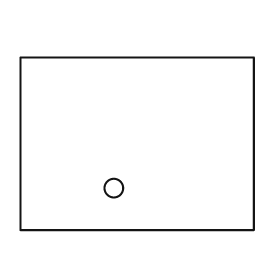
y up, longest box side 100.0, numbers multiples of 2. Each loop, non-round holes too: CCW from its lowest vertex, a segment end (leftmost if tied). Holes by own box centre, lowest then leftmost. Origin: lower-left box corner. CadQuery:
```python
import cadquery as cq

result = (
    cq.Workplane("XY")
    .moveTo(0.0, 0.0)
    .lineTo(100.0, 0.0)
    .lineTo(100.0, 74.0)
    .lineTo(0.0, 74.0)
    .close()
    .moveTo(40.0, 18.0)
    .circle(4.0)
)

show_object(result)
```